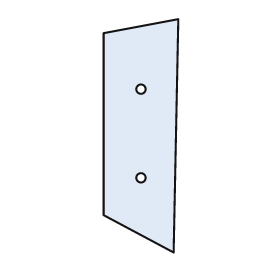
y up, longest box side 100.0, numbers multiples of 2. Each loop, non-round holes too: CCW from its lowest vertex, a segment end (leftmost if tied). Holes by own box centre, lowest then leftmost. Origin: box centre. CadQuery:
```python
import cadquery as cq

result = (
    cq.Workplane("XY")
    .moveTo(14.0, -50.0)
    .lineTo(16.0, 50.0)
    .lineTo(-16.0, 44.0)
    .lineTo(-16.0, -34.0)
    .close()
    .moveTo(0.0, -18.0)
    .circle(2.0)
    .moveTo(0.0, 20.0)
    .circle(2.0)
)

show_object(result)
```